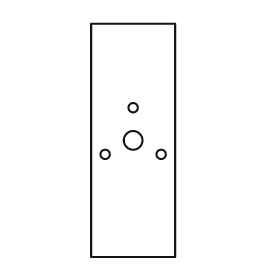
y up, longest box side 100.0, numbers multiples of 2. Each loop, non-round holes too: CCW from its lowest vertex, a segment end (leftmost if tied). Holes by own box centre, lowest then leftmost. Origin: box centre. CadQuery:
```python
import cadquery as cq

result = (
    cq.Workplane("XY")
    .moveTo(-18.0, -50.0)
    .lineTo(18.0, -50.0)
    .lineTo(18.0, 50.0)
    .lineTo(-18.0, 50.0)
    .close()
    .moveTo(-12.0, -6.0)
    .circle(2.0)
    .moveTo(12.0, -6.0)
    .circle(2.0)
    .moveTo(0.0, 0.0)
    .circle(4.0)
    .moveTo(0.0, 14.0)
    .circle(2.0)
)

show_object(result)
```